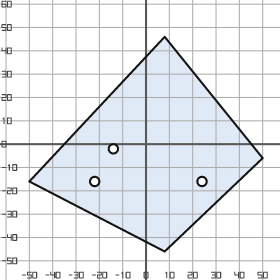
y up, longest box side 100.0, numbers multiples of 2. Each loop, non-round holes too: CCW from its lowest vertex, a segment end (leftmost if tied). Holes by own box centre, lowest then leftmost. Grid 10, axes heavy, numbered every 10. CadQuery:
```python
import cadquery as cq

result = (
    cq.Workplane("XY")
    .moveTo(8.0, -46.0)
    .lineTo(50.0, -6.0)
    .lineTo(8.0, 46.0)
    .lineTo(-50.0, -16.0)
    .close()
    .moveTo(-22.0, -16.0)
    .circle(2.0)
    .moveTo(24.0, -16.0)
    .circle(2.0)
    .moveTo(-14.0, -2.0)
    .circle(2.0)
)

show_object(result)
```